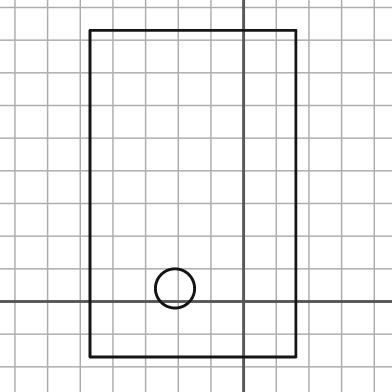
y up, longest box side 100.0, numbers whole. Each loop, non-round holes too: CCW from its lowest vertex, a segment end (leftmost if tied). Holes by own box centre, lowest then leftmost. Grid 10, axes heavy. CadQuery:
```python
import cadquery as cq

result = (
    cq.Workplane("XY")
    .moveTo(-47.0, -17.0)
    .lineTo(16.0, -17.0)
    .lineTo(16.0, 83.0)
    .lineTo(-47.0, 83.0)
    .close()
    .moveTo(-21.0, 4.0)
    .circle(6.0)
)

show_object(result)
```